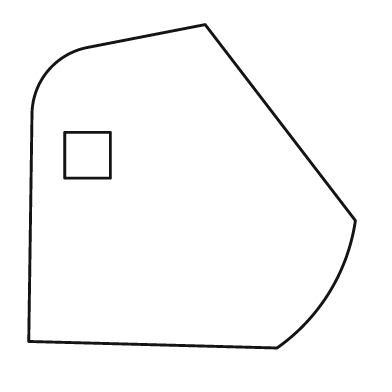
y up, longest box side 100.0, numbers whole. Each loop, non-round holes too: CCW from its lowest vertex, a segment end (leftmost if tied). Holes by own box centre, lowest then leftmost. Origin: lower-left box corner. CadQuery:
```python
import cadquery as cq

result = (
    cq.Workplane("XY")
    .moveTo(76.0, 0.0)
    .threePointArc((92.0, 17.0), (100.0, 39.0))
    .lineTo(54.0, 99.0)
    .lineTo(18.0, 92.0)
    .threePointArc((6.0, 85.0), (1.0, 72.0))
    .lineTo(0.0, 2.0)
    .close()
    .moveTo(11.0, 52.0)
    .lineTo(25.0, 52.0)
    .lineTo(25.0, 66.0)
    .lineTo(11.0, 66.0)
    .close()
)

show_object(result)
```